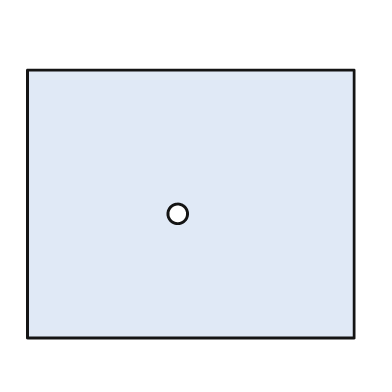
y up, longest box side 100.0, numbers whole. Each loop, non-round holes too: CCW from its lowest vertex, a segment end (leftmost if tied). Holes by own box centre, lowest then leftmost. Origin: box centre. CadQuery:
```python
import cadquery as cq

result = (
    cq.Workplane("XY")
    .moveTo(-50.0, -41.0)
    .lineTo(50.0, -41.0)
    .lineTo(50.0, 41.0)
    .lineTo(-50.0, 41.0)
    .close()
    .moveTo(-4.0, -3.0)
    .circle(3.0)
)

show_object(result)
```